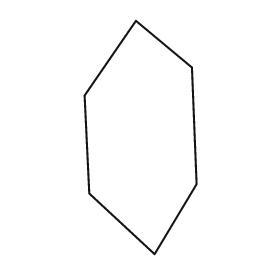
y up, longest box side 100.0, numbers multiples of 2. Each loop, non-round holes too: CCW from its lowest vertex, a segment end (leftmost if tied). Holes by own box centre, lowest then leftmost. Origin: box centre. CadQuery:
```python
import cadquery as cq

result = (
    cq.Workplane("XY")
    .moveTo(6.0, -50.0)
    .lineTo(24.0, -20.0)
    .lineTo(22.0, 30.0)
    .lineTo(-2.0, 50.0)
    .lineTo(-24.0, 18.0)
    .lineTo(-22.0, -24.0)
    .close()
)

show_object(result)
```